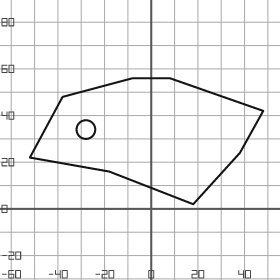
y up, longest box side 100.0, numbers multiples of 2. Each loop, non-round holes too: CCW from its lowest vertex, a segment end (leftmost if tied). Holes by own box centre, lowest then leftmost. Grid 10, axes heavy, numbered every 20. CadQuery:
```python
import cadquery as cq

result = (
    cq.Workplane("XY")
    .moveTo(18.0, 2.0)
    .lineTo(38.0, 24.0)
    .lineTo(48.0, 42.0)
    .lineTo(8.0, 56.0)
    .lineTo(-8.0, 56.0)
    .lineTo(-38.0, 48.0)
    .lineTo(-52.0, 22.0)
    .lineTo(-18.0, 16.0)
    .close()
    .moveTo(-28.0, 34.0)
    .circle(4.0)
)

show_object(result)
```